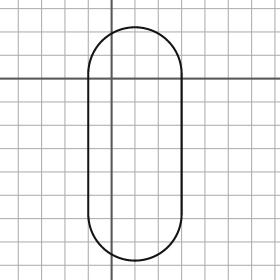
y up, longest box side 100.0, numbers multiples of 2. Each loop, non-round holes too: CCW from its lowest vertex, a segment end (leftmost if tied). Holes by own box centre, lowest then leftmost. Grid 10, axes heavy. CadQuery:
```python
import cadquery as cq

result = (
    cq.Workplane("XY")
    .moveTo(-10.0, -58.0)
    .threePointArc((10.0, -78.0), (30.0, -58.0))
    .lineTo(30.0, 2.0)
    .threePointArc((10.0, 22.0), (-10.0, 2.0))
    .close()
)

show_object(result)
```